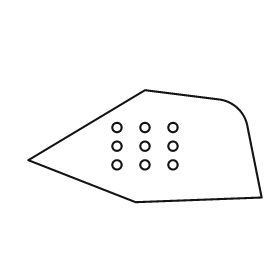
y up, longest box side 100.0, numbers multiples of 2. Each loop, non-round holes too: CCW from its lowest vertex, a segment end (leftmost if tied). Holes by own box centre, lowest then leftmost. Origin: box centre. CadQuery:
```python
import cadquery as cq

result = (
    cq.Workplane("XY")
    .moveTo(-4.0, -24.0)
    .lineTo(50.0, -22.0)
    .lineTo(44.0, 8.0)
    .threePointArc((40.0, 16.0), (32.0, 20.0))
    .lineTo(0.0, 24.0)
    .lineTo(-50.0, -6.0)
    .close()
    .moveTo(-12.0, -8.0)
    .circle(2.0)
    .moveTo(0.0, -8.0)
    .circle(2.0)
    .moveTo(12.0, -8.0)
    .circle(2.0)
    .moveTo(-12.0, 0.0)
    .circle(2.0)
    .moveTo(0.0, 0.0)
    .circle(2.0)
    .moveTo(12.0, 0.0)
    .circle(2.0)
    .moveTo(-12.0, 8.0)
    .circle(2.0)
    .moveTo(0.0, 8.0)
    .circle(2.0)
    .moveTo(12.0, 8.0)
    .circle(2.0)
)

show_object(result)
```